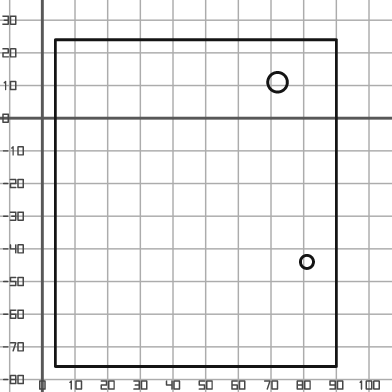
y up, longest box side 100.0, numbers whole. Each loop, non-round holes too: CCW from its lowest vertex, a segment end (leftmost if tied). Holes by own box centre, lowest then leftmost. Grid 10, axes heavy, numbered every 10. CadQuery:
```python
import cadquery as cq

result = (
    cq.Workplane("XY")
    .moveTo(4.0, -76.0)
    .lineTo(90.0, -76.0)
    .lineTo(90.0, 24.0)
    .lineTo(4.0, 24.0)
    .close()
    .moveTo(81.0, -44.0)
    .circle(2.0)
    .moveTo(72.0, 11.0)
    .circle(3.0)
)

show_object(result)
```